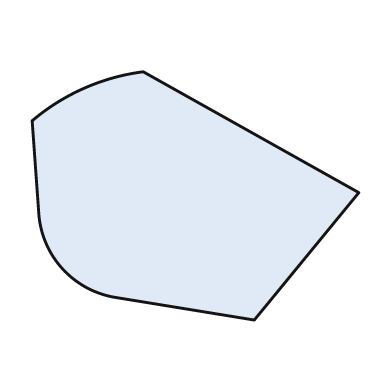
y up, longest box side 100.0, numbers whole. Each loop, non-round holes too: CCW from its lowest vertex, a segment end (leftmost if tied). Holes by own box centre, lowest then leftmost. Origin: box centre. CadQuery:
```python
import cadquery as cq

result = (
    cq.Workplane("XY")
    .moveTo(18.0, -38.0)
    .lineTo(50.0, 1.0)
    .lineTo(-16.0, 38.0)
    .threePointArc((-34.0, 33.0), (-50.0, 23.0))
    .lineTo(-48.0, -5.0)
    .threePointArc((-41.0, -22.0), (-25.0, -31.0))
    .close()
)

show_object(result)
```